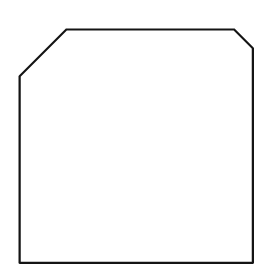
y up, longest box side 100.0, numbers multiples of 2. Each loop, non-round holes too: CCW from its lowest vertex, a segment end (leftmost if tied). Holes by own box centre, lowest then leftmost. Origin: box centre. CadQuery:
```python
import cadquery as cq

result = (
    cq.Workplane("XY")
    .moveTo(-50.0, -50.0)
    .lineTo(50.0, -50.0)
    .lineTo(50.0, 42.0)
    .lineTo(42.0, 50.0)
    .lineTo(-30.0, 50.0)
    .lineTo(-50.0, 30.0)
    .close()
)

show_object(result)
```